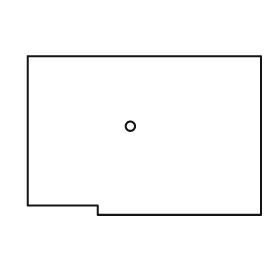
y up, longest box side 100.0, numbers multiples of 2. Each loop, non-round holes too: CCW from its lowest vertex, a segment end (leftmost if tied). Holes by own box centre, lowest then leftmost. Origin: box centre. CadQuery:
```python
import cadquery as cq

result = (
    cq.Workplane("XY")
    .moveTo(-20.0, -34.0)
    .lineTo(50.0, -34.0)
    .lineTo(50.0, 34.0)
    .lineTo(-50.0, 34.0)
    .lineTo(-50.0, -30.0)
    .lineTo(-20.0, -30.0)
    .close()
    .moveTo(-6.0, 4.0)
    .circle(2.0)
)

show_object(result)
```